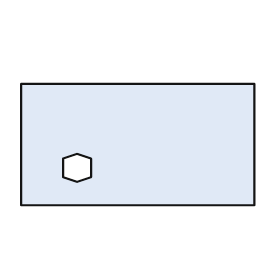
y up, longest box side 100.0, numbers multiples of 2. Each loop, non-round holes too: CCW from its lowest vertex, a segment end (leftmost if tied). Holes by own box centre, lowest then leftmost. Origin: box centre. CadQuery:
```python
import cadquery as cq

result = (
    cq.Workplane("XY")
    .moveTo(-50.0, -26.0)
    .lineTo(50.0, -26.0)
    .lineTo(50.0, 26.0)
    .lineTo(-50.0, 26.0)
    .close()
    .moveTo(-26.0, -16.0)
    .lineTo(-20.0, -14.0)
    .lineTo(-20.0, -6.0)
    .lineTo(-26.0, -4.0)
    .lineTo(-32.0, -6.0)
    .lineTo(-32.0, -14.0)
    .close()
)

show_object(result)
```